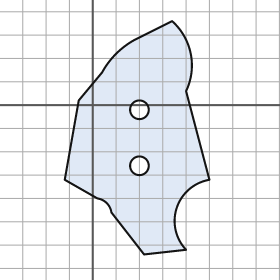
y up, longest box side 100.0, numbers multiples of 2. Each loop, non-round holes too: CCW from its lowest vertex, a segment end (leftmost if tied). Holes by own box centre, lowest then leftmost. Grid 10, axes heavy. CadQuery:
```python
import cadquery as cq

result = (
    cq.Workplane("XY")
    .moveTo(22.0, -64.0)
    .lineTo(40.0, -62.0)
    .threePointArc((36.0, -44.0), (50.0, -32.0))
    .lineTo(40.0, 6.0)
    .threePointArc((42.0, 22.0), (34.0, 36.0))
    .lineTo(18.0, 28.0)
    .threePointArc((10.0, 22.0), (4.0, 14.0))
    .lineTo(-6.0, 2.0)
    .lineTo(-12.0, -32.0)
    .lineTo(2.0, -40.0)
    .threePointArc((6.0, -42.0), (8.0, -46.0))
    .close()
    .moveTo(20.0, -26.0)
    .circle(4.0)
    .moveTo(20.0, -2.0)
    .circle(4.0)
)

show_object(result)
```